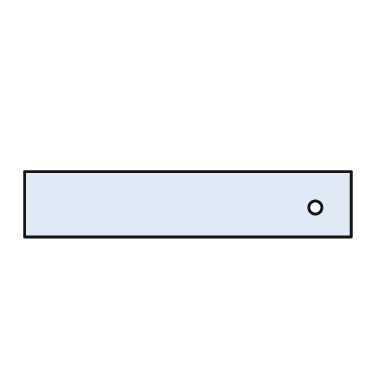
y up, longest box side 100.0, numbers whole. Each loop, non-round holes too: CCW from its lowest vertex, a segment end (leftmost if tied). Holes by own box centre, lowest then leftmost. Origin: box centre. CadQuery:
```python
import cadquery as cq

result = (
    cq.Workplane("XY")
    .moveTo(-50.0, -10.0)
    .lineTo(50.0, -10.0)
    .lineTo(50.0, 10.0)
    .lineTo(-50.0, 10.0)
    .close()
    .moveTo(39.0, -1.0)
    .circle(2.0)
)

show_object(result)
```